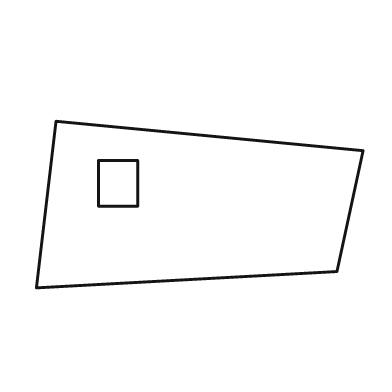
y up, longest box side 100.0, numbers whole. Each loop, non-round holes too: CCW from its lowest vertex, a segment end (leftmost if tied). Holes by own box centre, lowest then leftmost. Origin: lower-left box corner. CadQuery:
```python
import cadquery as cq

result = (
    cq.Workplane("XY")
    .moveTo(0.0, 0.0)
    .lineTo(92.0, 5.0)
    .lineTo(100.0, 42.0)
    .lineTo(6.0, 51.0)
    .close()
    .moveTo(19.0, 25.0)
    .lineTo(31.0, 25.0)
    .lineTo(31.0, 39.0)
    .lineTo(19.0, 39.0)
    .close()
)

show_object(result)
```